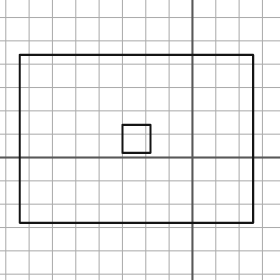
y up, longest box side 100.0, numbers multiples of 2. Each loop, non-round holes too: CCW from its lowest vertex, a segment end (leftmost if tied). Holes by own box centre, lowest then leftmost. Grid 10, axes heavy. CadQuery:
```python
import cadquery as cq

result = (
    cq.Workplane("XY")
    .moveTo(-74.0, -28.0)
    .lineTo(26.0, -28.0)
    .lineTo(26.0, 44.0)
    .lineTo(-74.0, 44.0)
    .close()
    .moveTo(-30.0, 2.0)
    .lineTo(-18.0, 2.0)
    .lineTo(-18.0, 14.0)
    .lineTo(-30.0, 14.0)
    .close()
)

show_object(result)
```